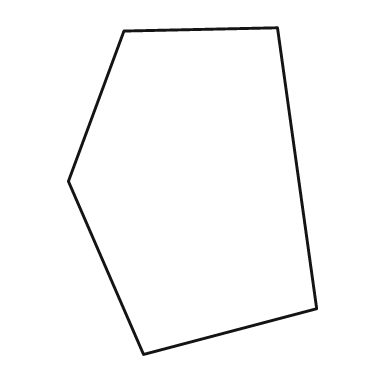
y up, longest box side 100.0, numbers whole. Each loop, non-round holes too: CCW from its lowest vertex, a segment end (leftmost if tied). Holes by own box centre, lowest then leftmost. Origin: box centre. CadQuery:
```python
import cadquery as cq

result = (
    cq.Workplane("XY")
    .moveTo(-15.0, -50.0)
    .lineTo(38.0, -36.0)
    .lineTo(26.0, 50.0)
    .lineTo(-21.0, 49.0)
    .lineTo(-38.0, 3.0)
    .close()
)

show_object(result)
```